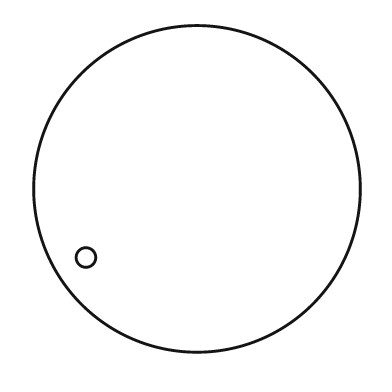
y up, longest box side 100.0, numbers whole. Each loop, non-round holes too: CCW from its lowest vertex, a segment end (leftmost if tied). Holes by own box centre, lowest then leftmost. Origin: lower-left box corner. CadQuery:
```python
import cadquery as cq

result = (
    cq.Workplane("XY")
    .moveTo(50.0, 50.0)
    .circle(50.0)
    .moveTo(16.0, 29.0)
    .circle(3.0)
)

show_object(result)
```